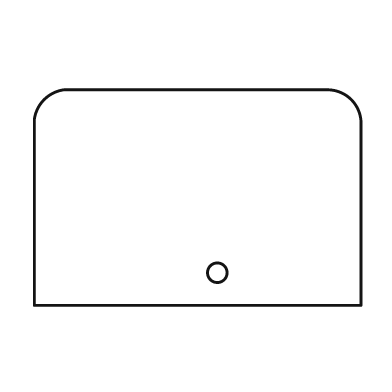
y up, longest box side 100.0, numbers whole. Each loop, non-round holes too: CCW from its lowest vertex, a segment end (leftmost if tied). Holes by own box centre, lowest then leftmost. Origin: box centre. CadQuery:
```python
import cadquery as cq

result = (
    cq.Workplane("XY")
    .moveTo(-50.0, -33.0)
    .lineTo(50.0, -33.0)
    .lineTo(50.0, 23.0)
    .threePointArc((47.0, 30.0), (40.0, 33.0))
    .lineTo(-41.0, 33.0)
    .threePointArc((-47.0, 30.0), (-50.0, 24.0))
    .close()
    .moveTo(6.0, -23.0)
    .circle(3.0)
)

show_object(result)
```